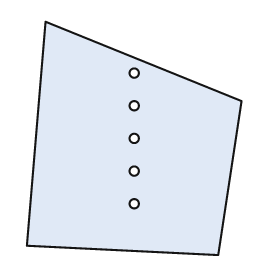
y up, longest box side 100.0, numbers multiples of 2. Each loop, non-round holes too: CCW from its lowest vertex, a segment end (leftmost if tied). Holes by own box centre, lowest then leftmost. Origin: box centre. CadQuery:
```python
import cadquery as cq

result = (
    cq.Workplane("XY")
    .moveTo(36.0, -50.0)
    .lineTo(46.0, 16.0)
    .lineTo(-38.0, 50.0)
    .lineTo(-46.0, -46.0)
    .close()
    .moveTo(0.0, -28.0)
    .circle(2.0)
    .moveTo(0.0, -14.0)
    .circle(2.0)
    .moveTo(0.0, 0.0)
    .circle(2.0)
    .moveTo(0.0, 14.0)
    .circle(2.0)
    .moveTo(0.0, 28.0)
    .circle(2.0)
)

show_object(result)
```